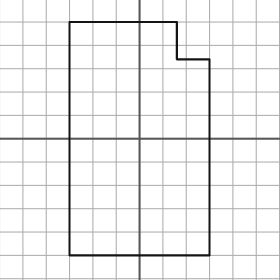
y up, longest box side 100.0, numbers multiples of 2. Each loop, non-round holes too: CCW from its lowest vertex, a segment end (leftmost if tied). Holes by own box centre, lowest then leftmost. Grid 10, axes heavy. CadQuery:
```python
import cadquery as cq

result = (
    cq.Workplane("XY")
    .moveTo(-30.0, -50.0)
    .lineTo(30.0, -50.0)
    .lineTo(30.0, 34.0)
    .lineTo(16.0, 34.0)
    .lineTo(16.0, 50.0)
    .lineTo(-30.0, 50.0)
    .close()
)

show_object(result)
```